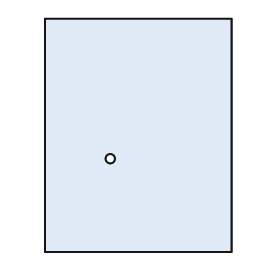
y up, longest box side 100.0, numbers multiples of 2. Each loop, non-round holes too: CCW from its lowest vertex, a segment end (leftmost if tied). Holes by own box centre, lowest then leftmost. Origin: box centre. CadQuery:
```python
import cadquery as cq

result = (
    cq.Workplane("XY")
    .moveTo(-40.0, -50.0)
    .lineTo(40.0, -50.0)
    .lineTo(40.0, 50.0)
    .lineTo(-40.0, 50.0)
    .close()
    .moveTo(-12.0, -10.0)
    .circle(2.0)
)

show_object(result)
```